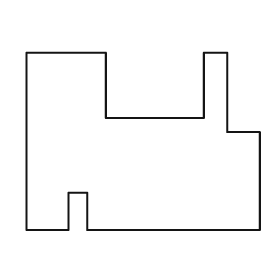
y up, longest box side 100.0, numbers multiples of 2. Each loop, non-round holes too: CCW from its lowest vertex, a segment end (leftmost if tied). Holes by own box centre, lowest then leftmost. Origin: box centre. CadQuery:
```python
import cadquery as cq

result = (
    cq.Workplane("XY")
    .moveTo(-50.0, -38.0)
    .lineTo(-32.0, -38.0)
    .lineTo(-32.0, -22.0)
    .lineTo(-24.0, -22.0)
    .lineTo(-24.0, -38.0)
    .lineTo(50.0, -38.0)
    .lineTo(50.0, 4.0)
    .lineTo(36.0, 4.0)
    .lineTo(36.0, 38.0)
    .lineTo(26.0, 38.0)
    .lineTo(26.0, 10.0)
    .lineTo(-16.0, 10.0)
    .lineTo(-16.0, 38.0)
    .lineTo(-50.0, 38.0)
    .close()
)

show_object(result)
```